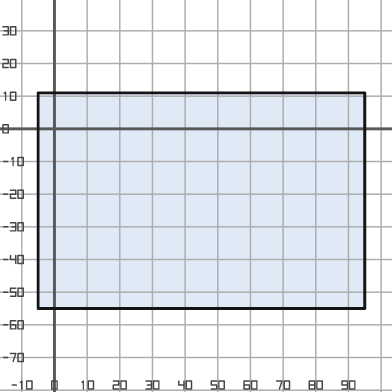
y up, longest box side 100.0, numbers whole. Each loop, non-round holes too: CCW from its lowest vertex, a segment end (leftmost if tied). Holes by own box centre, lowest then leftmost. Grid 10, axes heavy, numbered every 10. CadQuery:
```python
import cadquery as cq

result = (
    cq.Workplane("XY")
    .moveTo(-5.0, -55.0)
    .lineTo(95.0, -55.0)
    .lineTo(95.0, 11.0)
    .lineTo(-5.0, 11.0)
    .close()
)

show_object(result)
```